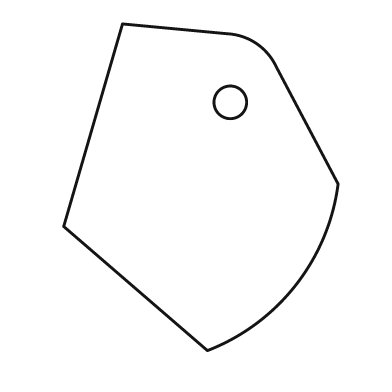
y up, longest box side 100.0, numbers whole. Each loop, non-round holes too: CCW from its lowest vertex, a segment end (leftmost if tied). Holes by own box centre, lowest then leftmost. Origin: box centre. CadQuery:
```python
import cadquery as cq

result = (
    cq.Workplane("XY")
    .moveTo(2.0, -50.0)
    .threePointArc((29.0, -30.0), (42.0, 1.0))
    .lineTo(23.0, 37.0)
    .threePointArc((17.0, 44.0), (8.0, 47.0))
    .lineTo(-24.0, 50.0)
    .lineTo(-42.0, -12.0)
    .close()
    .moveTo(9.0, 26.0)
    .circle(5.0)
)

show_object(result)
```